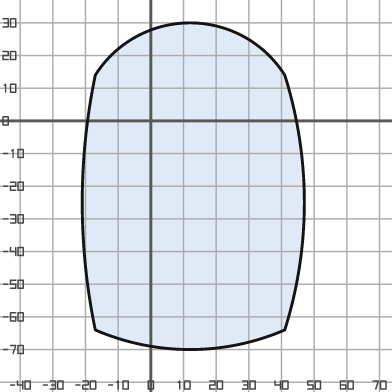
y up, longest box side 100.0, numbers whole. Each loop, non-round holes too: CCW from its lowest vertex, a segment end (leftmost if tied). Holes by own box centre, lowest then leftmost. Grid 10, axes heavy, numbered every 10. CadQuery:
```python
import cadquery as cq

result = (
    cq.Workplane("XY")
    .moveTo(-17.0, -64.0)
    .threePointArc((12.0, -70.0), (41.0, -64.0))
    .threePointArc((47.0, -25.0), (41.0, 14.0))
    .threePointArc((12.0, 30.0), (-17.0, 14.0))
    .threePointArc((-21.0, -25.0), (-17.0, -64.0))
    .close()
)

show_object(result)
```